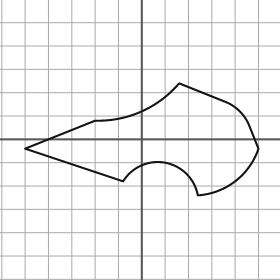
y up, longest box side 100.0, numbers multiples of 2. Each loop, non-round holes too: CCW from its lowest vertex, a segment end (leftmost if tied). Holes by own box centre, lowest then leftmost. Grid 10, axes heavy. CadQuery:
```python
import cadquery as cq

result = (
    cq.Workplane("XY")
    .moveTo(24.0, -24.0)
    .threePointArc((40.0, -18.0), (50.0, -4.0))
    .lineTo(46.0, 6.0)
    .threePointArc((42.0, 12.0), (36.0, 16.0))
    .lineTo(16.0, 24.0)
    .threePointArc((0.0, 12.0), (-20.0, 8.0))
    .lineTo(-50.0, -4.0)
    .lineTo(-8.0, -18.0)
    .threePointArc((10.0, -10.0), (24.0, -24.0))
    .close()
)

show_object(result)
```